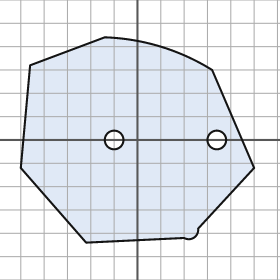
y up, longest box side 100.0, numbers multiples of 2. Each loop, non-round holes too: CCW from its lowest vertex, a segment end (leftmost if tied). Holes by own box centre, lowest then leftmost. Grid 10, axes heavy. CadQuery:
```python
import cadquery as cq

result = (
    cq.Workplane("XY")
    .moveTo(-22.0, -44.0)
    .lineTo(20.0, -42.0)
    .threePointArc((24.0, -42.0), (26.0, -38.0))
    .lineTo(50.0, -12.0)
    .lineTo(32.0, 30.0)
    .threePointArc((10.0, 40.0), (-14.0, 44.0))
    .lineTo(-46.0, 32.0)
    .lineTo(-50.0, -12.0)
    .close()
    .moveTo(-10.0, 0.0)
    .circle(4.0)
    .moveTo(34.0, 0.0)
    .circle(4.0)
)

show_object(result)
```